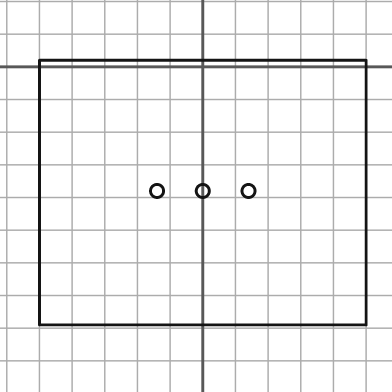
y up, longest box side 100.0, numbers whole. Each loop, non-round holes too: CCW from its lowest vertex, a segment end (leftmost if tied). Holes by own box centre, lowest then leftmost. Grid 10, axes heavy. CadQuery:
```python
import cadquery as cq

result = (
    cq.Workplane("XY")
    .moveTo(-50.0, -79.0)
    .lineTo(50.0, -79.0)
    .lineTo(50.0, 2.0)
    .lineTo(-50.0, 2.0)
    .close()
    .moveTo(-14.0, -38.0)
    .circle(2.0)
    .moveTo(0.0, -38.0)
    .circle(2.0)
    .moveTo(14.0, -38.0)
    .circle(2.0)
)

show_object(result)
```